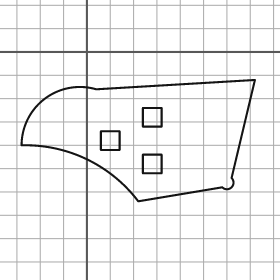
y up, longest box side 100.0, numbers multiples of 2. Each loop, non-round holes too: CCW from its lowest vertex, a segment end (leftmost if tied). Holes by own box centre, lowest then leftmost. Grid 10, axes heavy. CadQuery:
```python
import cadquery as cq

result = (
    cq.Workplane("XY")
    .moveTo(22.0, -64.0)
    .lineTo(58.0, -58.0)
    .threePointArc((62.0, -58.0), (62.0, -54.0))
    .lineTo(72.0, -12.0)
    .lineTo(4.0, -16.0)
    .threePointArc((-18.0, -20.0), (-28.0, -40.0))
    .threePointArc((0.0, -46.0), (22.0, -64.0))
    .close()
    .moveTo(24.0, -52.0)
    .lineTo(32.0, -52.0)
    .lineTo(32.0, -44.0)
    .lineTo(24.0, -44.0)
    .close()
    .moveTo(6.0, -42.0)
    .lineTo(14.0, -42.0)
    .lineTo(14.0, -34.0)
    .lineTo(6.0, -34.0)
    .close()
    .moveTo(24.0, -32.0)
    .lineTo(32.0, -32.0)
    .lineTo(32.0, -24.0)
    .lineTo(24.0, -24.0)
    .close()
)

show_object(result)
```